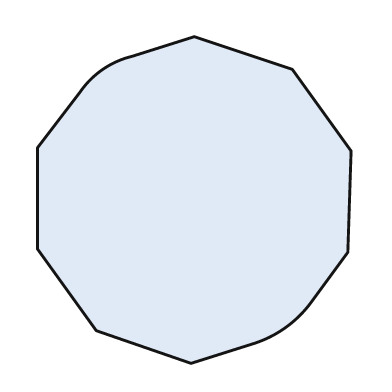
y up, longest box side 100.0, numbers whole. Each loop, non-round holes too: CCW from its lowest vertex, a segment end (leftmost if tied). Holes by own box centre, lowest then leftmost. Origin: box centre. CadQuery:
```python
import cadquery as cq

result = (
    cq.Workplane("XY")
    .moveTo(-1.0, -50.0)
    .lineTo(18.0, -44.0)
    .threePointArc((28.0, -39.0), (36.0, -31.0))
    .lineTo(47.0, -16.0)
    .lineTo(48.0, 15.0)
    .lineTo(30.0, 40.0)
    .lineTo(0.0, 50.0)
    .lineTo(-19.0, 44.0)
    .threePointArc((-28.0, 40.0), (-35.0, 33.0))
    .lineTo(-48.0, 16.0)
    .lineTo(-48.0, -15.0)
    .lineTo(-30.0, -40.0)
    .close()
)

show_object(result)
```